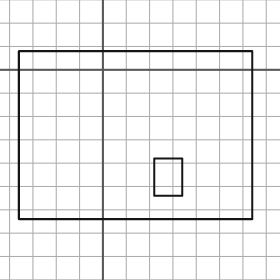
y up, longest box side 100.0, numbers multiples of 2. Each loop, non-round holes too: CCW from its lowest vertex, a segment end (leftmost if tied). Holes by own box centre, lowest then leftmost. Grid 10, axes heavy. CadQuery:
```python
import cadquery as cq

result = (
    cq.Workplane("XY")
    .moveTo(-36.0, -64.0)
    .lineTo(64.0, -64.0)
    .lineTo(64.0, 8.0)
    .lineTo(-36.0, 8.0)
    .close()
    .moveTo(22.0, -54.0)
    .lineTo(34.0, -54.0)
    .lineTo(34.0, -38.0)
    .lineTo(22.0, -38.0)
    .close()
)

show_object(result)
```